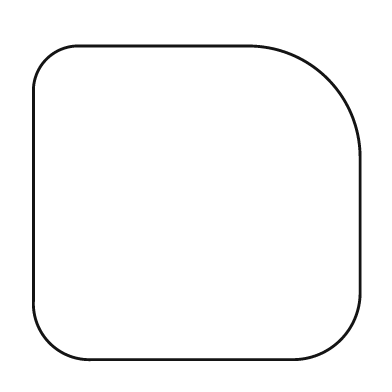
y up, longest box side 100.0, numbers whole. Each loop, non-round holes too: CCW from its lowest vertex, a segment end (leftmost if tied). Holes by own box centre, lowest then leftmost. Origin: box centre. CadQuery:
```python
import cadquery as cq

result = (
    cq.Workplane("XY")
    .moveTo(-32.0, -48.0)
    .lineTo(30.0, -48.0)
    .threePointArc((44.0, -42.0), (50.0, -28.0))
    .lineTo(50.0, 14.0)
    .threePointArc((40.0, 38.0), (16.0, 48.0))
    .lineTo(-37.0, 48.0)
    .threePointArc((-46.0, 44.0), (-50.0, 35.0))
    .lineTo(-50.0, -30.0)
    .threePointArc((-45.0, -43.0), (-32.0, -48.0))
    .close()
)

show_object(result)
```